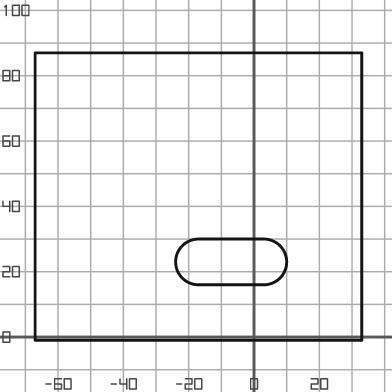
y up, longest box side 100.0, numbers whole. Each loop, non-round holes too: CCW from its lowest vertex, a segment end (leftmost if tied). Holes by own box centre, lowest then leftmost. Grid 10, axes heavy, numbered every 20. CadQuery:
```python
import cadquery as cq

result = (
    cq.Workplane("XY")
    .moveTo(-67.0, -1.0)
    .lineTo(33.0, -1.0)
    .lineTo(33.0, 87.0)
    .lineTo(-67.0, 87.0)
    .close()
    .moveTo(-17.0, 16.0)
    .lineTo(3.0, 16.0)
    .threePointArc((10.0, 23.0), (3.0, 30.0))
    .lineTo(-17.0, 30.0)
    .threePointArc((-24.0, 23.0), (-17.0, 16.0))
    .close()
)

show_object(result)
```